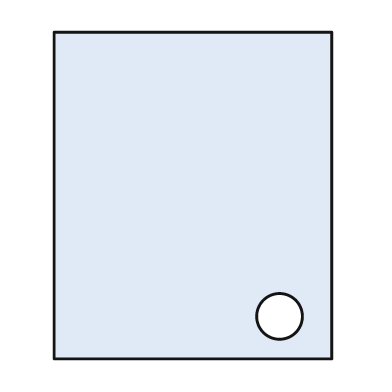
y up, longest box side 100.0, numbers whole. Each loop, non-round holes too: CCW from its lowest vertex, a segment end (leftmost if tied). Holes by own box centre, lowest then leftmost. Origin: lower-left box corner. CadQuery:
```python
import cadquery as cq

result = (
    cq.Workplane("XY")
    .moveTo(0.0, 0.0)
    .lineTo(85.0, 0.0)
    .lineTo(85.0, 100.0)
    .lineTo(0.0, 100.0)
    .close()
    .moveTo(69.0, 13.0)
    .circle(7.0)
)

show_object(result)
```